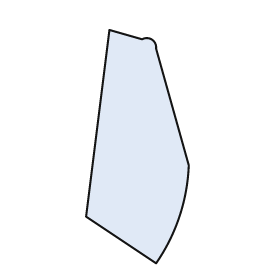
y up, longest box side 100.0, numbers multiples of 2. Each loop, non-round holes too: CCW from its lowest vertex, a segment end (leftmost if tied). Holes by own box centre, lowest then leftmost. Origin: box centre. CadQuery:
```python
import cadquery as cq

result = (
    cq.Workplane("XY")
    .moveTo(8.0, -50.0)
    .threePointArc((18.0, -30.0), (22.0, -8.0))
    .lineTo(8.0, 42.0)
    .threePointArc((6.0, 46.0), (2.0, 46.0))
    .lineTo(-12.0, 50.0)
    .lineTo(-22.0, -30.0)
    .close()
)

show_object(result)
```